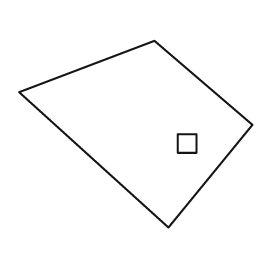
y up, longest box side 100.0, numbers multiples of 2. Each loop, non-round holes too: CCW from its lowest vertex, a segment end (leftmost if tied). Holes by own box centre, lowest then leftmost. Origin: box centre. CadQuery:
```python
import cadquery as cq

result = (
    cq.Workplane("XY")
    .moveTo(14.0, -40.0)
    .lineTo(50.0, 4.0)
    .lineTo(8.0, 40.0)
    .lineTo(-50.0, 18.0)
    .close()
    .moveTo(18.0, -8.0)
    .lineTo(26.0, -8.0)
    .lineTo(26.0, 0.0)
    .lineTo(18.0, 0.0)
    .close()
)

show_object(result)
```